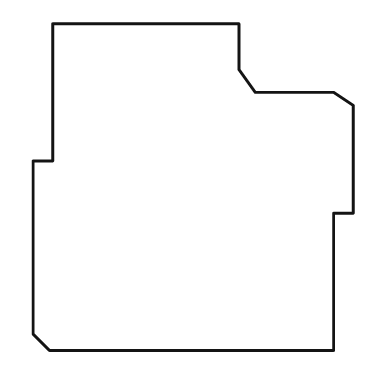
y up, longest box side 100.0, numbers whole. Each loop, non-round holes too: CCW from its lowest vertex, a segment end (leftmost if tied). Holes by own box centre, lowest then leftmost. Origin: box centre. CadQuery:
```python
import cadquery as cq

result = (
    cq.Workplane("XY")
    .moveTo(-44.0, -50.0)
    .lineTo(43.0, -50.0)
    .lineTo(43.0, -8.0)
    .lineTo(49.0, -8.0)
    .lineTo(49.0, 25.0)
    .lineTo(43.0, 29.0)
    .lineTo(19.0, 29.0)
    .lineTo(14.0, 36.0)
    .lineTo(14.0, 50.0)
    .lineTo(-43.0, 50.0)
    .lineTo(-43.0, 8.0)
    .lineTo(-49.0, 8.0)
    .lineTo(-49.0, -45.0)
    .close()
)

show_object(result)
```